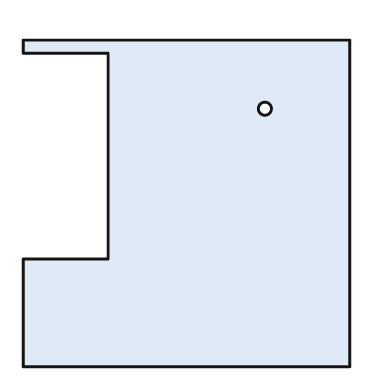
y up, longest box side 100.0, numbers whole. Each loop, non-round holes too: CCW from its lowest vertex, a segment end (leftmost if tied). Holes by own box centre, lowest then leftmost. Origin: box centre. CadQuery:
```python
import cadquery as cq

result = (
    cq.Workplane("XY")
    .moveTo(-50.0, -50.0)
    .lineTo(50.0, -50.0)
    .lineTo(50.0, 50.0)
    .lineTo(-50.0, 50.0)
    .lineTo(-50.0, 46.0)
    .lineTo(-24.0, 46.0)
    .lineTo(-24.0, -17.0)
    .lineTo(-50.0, -17.0)
    .close()
    .moveTo(24.0, 29.0)
    .circle(2.0)
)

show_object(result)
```